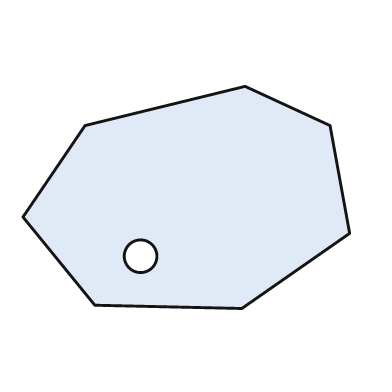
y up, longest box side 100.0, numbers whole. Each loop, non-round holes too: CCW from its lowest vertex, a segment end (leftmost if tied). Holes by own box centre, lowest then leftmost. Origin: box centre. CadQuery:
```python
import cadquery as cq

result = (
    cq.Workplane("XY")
    .moveTo(17.0, -34.0)
    .lineTo(50.0, -11.0)
    .lineTo(44.0, 22.0)
    .lineTo(18.0, 34.0)
    .lineTo(-31.0, 22.0)
    .lineTo(-50.0, -6.0)
    .lineTo(-28.0, -33.0)
    .close()
    .moveTo(-14.0, -18.0)
    .circle(5.0)
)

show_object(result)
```